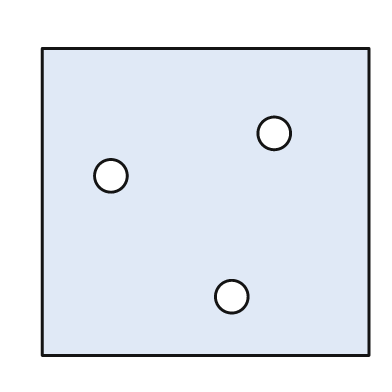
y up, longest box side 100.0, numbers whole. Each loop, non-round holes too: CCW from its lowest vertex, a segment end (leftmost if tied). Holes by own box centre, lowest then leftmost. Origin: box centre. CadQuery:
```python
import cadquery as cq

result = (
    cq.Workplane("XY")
    .moveTo(-50.0, -47.0)
    .lineTo(50.0, -47.0)
    .lineTo(50.0, 47.0)
    .lineTo(-50.0, 47.0)
    .close()
    .moveTo(8.0, -29.0)
    .circle(5.0)
    .moveTo(-29.0, 8.0)
    .circle(5.0)
    .moveTo(21.0, 21.0)
    .circle(5.0)
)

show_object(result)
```